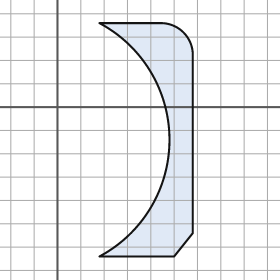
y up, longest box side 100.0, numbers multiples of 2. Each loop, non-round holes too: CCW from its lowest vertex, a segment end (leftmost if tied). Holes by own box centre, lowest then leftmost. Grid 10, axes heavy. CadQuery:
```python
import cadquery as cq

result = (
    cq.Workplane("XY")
    .moveTo(18.0, -64.0)
    .lineTo(50.0, -64.0)
    .lineTo(58.0, -54.0)
    .lineTo(58.0, 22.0)
    .threePointArc((54.0, 32.0), (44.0, 36.0))
    .lineTo(18.0, 36.0)
    .threePointArc((48.0, -14.0), (18.0, -64.0))
    .close()
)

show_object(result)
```